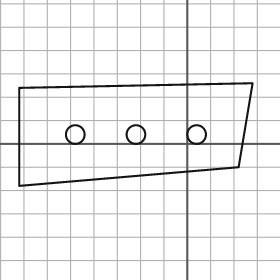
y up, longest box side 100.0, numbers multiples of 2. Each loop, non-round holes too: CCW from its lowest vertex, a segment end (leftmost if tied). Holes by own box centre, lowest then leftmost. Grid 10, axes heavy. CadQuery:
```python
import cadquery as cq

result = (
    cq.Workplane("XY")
    .moveTo(-72.0, -18.0)
    .lineTo(22.0, -10.0)
    .lineTo(28.0, 26.0)
    .lineTo(-72.0, 24.0)
    .close()
    .moveTo(-48.0, 4.0)
    .circle(4.0)
    .moveTo(-22.0, 4.0)
    .circle(4.0)
    .moveTo(4.0, 4.0)
    .circle(4.0)
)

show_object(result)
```